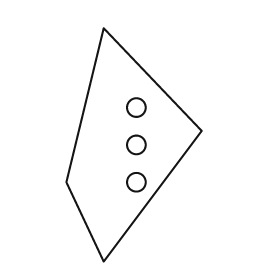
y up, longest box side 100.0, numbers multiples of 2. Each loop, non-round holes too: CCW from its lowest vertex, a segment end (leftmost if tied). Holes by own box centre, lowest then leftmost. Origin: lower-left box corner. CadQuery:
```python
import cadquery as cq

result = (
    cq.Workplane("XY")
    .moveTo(16.0, 0.0)
    .lineTo(58.0, 56.0)
    .lineTo(16.0, 100.0)
    .lineTo(0.0, 34.0)
    .close()
    .moveTo(30.0, 34.0)
    .circle(4.0)
    .moveTo(30.0, 50.0)
    .circle(4.0)
    .moveTo(30.0, 66.0)
    .circle(4.0)
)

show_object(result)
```